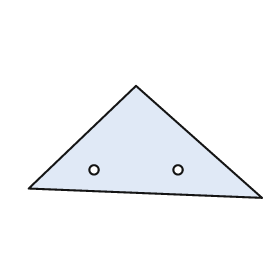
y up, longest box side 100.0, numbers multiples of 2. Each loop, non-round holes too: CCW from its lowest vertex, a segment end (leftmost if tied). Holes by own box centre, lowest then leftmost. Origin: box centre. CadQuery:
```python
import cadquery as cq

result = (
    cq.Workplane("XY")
    .moveTo(50.0, -24.0)
    .lineTo(-4.0, 24.0)
    .lineTo(-50.0, -20.0)
    .close()
    .moveTo(-22.0, -12.0)
    .circle(2.0)
    .moveTo(14.0, -12.0)
    .circle(2.0)
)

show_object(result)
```